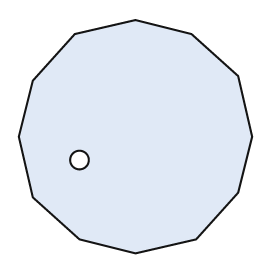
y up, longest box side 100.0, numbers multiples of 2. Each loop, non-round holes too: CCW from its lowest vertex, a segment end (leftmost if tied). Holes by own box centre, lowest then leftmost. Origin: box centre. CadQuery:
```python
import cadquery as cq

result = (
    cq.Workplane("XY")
    .moveTo(0.0, -50.0)
    .lineTo(26.0, -44.0)
    .lineTo(44.0, -24.0)
    .lineTo(50.0, 0.0)
    .lineTo(44.0, 26.0)
    .lineTo(24.0, 44.0)
    .lineTo(0.0, 50.0)
    .lineTo(-26.0, 44.0)
    .lineTo(-44.0, 24.0)
    .lineTo(-50.0, 0.0)
    .lineTo(-44.0, -26.0)
    .lineTo(-24.0, -44.0)
    .close()
    .moveTo(-24.0, -10.0)
    .circle(4.0)
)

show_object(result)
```